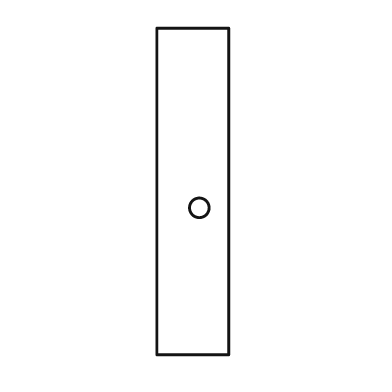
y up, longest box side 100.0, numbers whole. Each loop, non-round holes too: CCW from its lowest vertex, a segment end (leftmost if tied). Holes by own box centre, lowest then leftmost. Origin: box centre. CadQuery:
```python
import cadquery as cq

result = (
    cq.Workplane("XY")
    .moveTo(-11.0, -50.0)
    .lineTo(11.0, -50.0)
    .lineTo(11.0, 50.0)
    .lineTo(-11.0, 50.0)
    .close()
    .moveTo(2.0, -5.0)
    .circle(3.0)
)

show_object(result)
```